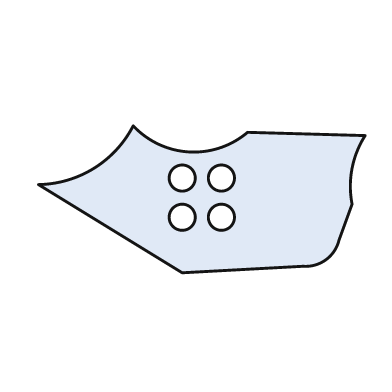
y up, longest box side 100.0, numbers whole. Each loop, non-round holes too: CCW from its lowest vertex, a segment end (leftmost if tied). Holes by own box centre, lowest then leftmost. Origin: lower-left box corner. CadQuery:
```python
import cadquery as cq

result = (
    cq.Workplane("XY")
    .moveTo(44.0, 0.0)
    .lineTo(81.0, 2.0)
    .threePointArc((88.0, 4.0), (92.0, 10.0))
    .lineTo(96.0, 21.0)
    .threePointArc((96.0, 32.0), (100.0, 42.0))
    .lineTo(64.0, 43.0)
    .threePointArc((46.0, 37.0), (29.0, 45.0))
    .threePointArc((17.0, 32.0), (0.0, 27.0))
    .close()
    .moveTo(44.0, 17.0)
    .circle(4.0)
    .moveTo(56.0, 17.0)
    .circle(4.0)
    .moveTo(44.0, 29.0)
    .circle(4.0)
    .moveTo(56.0, 29.0)
    .circle(4.0)
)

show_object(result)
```